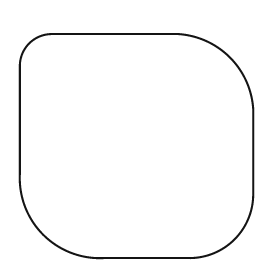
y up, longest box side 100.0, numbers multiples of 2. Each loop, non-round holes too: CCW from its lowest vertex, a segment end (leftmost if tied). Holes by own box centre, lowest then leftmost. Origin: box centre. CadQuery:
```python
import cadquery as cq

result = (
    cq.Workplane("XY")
    .moveTo(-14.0, -48.0)
    .lineTo(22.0, -48.0)
    .threePointArc((42.0, -40.0), (50.0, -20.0))
    .lineTo(50.0, 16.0)
    .threePointArc((40.0, 38.0), (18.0, 48.0))
    .lineTo(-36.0, 48.0)
    .threePointArc((-46.0, 44.0), (-50.0, 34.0))
    .lineTo(-50.0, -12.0)
    .threePointArc((-40.0, -38.0), (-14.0, -48.0))
    .close()
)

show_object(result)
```